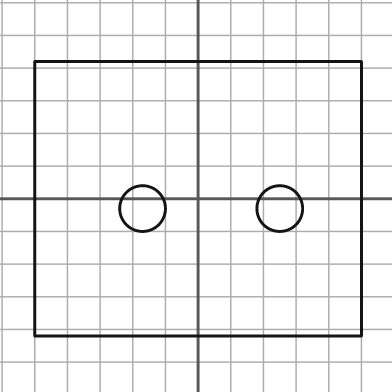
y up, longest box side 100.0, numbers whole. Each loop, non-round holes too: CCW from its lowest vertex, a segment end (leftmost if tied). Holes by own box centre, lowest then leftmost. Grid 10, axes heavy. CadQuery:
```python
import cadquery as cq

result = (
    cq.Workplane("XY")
    .moveTo(-50.0, -42.0)
    .lineTo(50.0, -42.0)
    .lineTo(50.0, 42.0)
    .lineTo(-50.0, 42.0)
    .close()
    .moveTo(-17.0, -3.0)
    .circle(7.0)
    .moveTo(25.0, -3.0)
    .circle(7.0)
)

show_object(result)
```